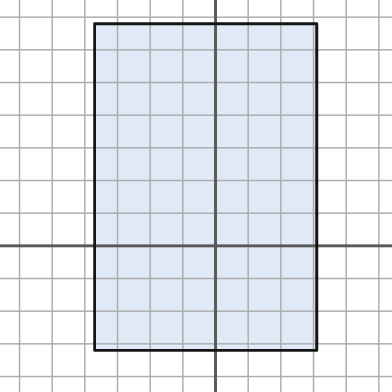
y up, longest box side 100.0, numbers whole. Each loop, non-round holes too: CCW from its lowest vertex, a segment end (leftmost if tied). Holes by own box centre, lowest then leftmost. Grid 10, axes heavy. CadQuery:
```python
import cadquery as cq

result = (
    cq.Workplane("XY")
    .moveTo(-37.0, -32.0)
    .lineTo(31.0, -32.0)
    .lineTo(31.0, 68.0)
    .lineTo(-37.0, 68.0)
    .close()
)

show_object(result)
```